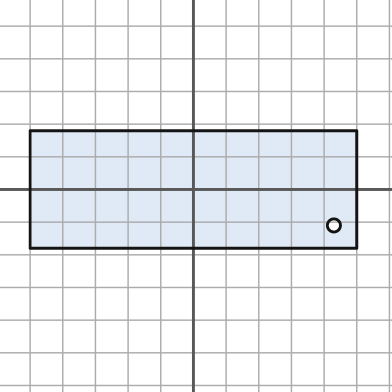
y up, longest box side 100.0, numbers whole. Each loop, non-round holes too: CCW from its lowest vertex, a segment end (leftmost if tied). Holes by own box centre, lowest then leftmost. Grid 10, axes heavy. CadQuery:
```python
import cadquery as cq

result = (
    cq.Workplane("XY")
    .moveTo(-50.0, -18.0)
    .lineTo(50.0, -18.0)
    .lineTo(50.0, 18.0)
    .lineTo(-50.0, 18.0)
    .close()
    .moveTo(43.0, -11.0)
    .circle(2.0)
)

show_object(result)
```